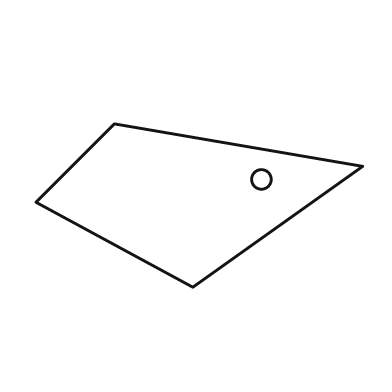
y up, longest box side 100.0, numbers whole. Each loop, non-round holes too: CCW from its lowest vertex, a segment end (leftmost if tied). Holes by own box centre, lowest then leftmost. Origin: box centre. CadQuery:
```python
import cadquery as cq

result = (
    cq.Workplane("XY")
    .moveTo(-2.0, -25.0)
    .lineTo(50.0, 12.0)
    .lineTo(-26.0, 25.0)
    .lineTo(-50.0, 1.0)
    .close()
    .moveTo(19.0, 8.0)
    .circle(3.0)
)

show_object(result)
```